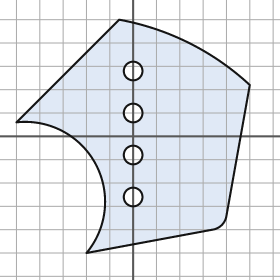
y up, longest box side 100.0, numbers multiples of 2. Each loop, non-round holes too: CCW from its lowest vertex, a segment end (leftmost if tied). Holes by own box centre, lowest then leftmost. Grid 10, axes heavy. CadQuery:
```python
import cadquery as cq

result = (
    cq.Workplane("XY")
    .moveTo(-20.0, -50.0)
    .lineTo(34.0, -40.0)
    .threePointArc((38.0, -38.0), (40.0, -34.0))
    .lineTo(50.0, 22.0)
    .threePointArc((24.0, 40.0), (-6.0, 50.0))
    .lineTo(-50.0, 6.0)
    .threePointArc((-16.0, -12.0), (-20.0, -50.0))
    .close()
    .moveTo(0.0, -26.0)
    .circle(4.0)
    .moveTo(0.0, -8.0)
    .circle(4.0)
    .moveTo(0.0, 10.0)
    .circle(4.0)
    .moveTo(0.0, 28.0)
    .circle(4.0)
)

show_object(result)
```